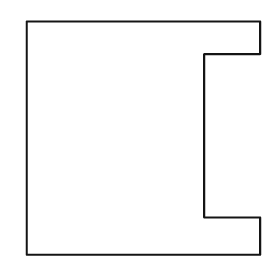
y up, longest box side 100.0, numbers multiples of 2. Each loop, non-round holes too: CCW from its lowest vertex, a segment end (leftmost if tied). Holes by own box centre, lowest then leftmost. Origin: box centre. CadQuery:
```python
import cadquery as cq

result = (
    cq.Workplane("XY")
    .moveTo(-50.0, -50.0)
    .lineTo(50.0, -50.0)
    .lineTo(50.0, -34.0)
    .lineTo(26.0, -34.0)
    .lineTo(26.0, 36.0)
    .lineTo(50.0, 36.0)
    .lineTo(50.0, 50.0)
    .lineTo(-50.0, 50.0)
    .close()
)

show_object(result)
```